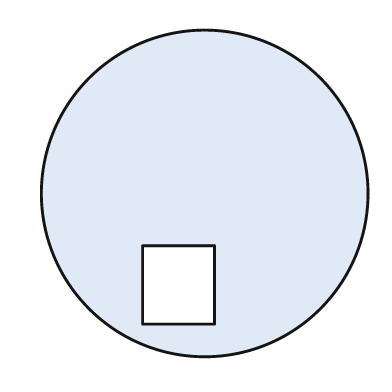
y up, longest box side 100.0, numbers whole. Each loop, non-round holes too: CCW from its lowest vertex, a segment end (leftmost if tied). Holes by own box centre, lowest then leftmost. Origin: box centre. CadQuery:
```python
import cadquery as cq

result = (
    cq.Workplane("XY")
    .moveTo(0.0, 0.0)
    .circle(50.0)
    .moveTo(-19.0, -40.0)
    .lineTo(3.0, -40.0)
    .lineTo(3.0, -16.0)
    .lineTo(-19.0, -16.0)
    .close()
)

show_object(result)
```